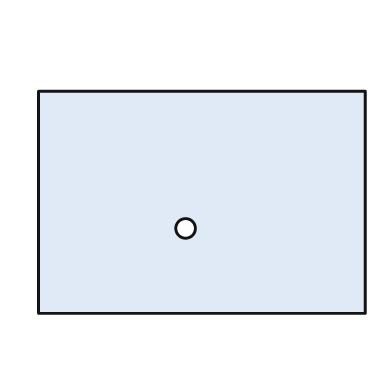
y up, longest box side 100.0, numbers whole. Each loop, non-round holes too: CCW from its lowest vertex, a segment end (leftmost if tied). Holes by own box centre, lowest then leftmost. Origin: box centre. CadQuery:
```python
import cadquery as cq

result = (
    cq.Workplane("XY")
    .moveTo(-50.0, -34.0)
    .lineTo(50.0, -34.0)
    .lineTo(50.0, 34.0)
    .lineTo(-50.0, 34.0)
    .close()
    .moveTo(-5.0, -8.0)
    .circle(3.0)
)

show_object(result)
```